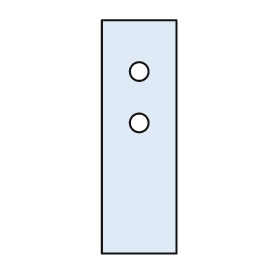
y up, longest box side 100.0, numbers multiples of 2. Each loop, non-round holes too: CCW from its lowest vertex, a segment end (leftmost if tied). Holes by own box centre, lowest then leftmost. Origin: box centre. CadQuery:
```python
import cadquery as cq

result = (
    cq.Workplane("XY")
    .moveTo(-16.0, -50.0)
    .lineTo(16.0, -50.0)
    .lineTo(16.0, 50.0)
    .lineTo(-16.0, 50.0)
    .close()
    .moveTo(0.0, 6.0)
    .circle(4.0)
    .moveTo(0.0, 28.0)
    .circle(4.0)
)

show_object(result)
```